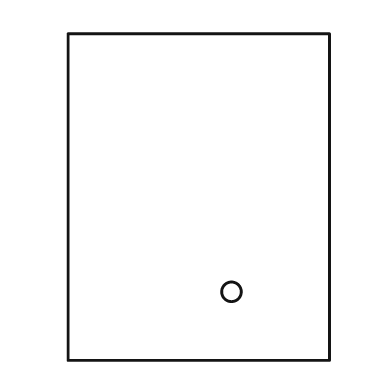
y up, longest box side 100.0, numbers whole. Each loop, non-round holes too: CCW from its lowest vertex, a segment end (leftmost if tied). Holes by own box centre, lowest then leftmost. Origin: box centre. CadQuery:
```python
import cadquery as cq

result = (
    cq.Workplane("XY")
    .moveTo(-40.0, -50.0)
    .lineTo(40.0, -50.0)
    .lineTo(40.0, 50.0)
    .lineTo(-40.0, 50.0)
    .close()
    .moveTo(10.0, -29.0)
    .circle(3.0)
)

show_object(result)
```